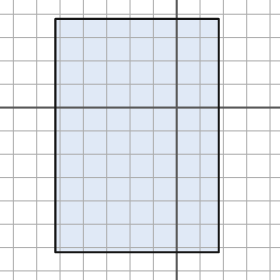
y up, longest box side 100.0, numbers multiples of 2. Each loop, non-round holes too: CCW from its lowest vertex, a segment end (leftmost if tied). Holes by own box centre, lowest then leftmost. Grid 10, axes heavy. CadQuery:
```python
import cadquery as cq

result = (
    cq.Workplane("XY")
    .moveTo(-52.0, -62.0)
    .lineTo(18.0, -62.0)
    .lineTo(18.0, 38.0)
    .lineTo(-52.0, 38.0)
    .close()
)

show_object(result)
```